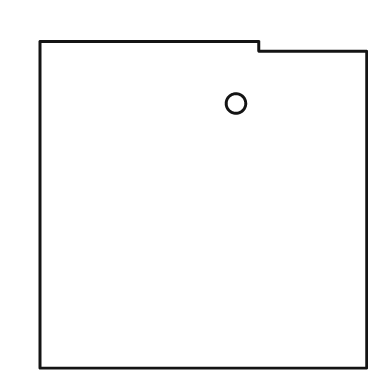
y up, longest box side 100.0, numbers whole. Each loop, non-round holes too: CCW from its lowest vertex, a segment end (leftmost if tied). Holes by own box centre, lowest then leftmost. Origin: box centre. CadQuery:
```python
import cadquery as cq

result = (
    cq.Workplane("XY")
    .moveTo(-50.0, -50.0)
    .lineTo(50.0, -50.0)
    .lineTo(50.0, 47.0)
    .lineTo(17.0, 47.0)
    .lineTo(17.0, 50.0)
    .lineTo(-50.0, 50.0)
    .close()
    .moveTo(10.0, 31.0)
    .circle(3.0)
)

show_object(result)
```